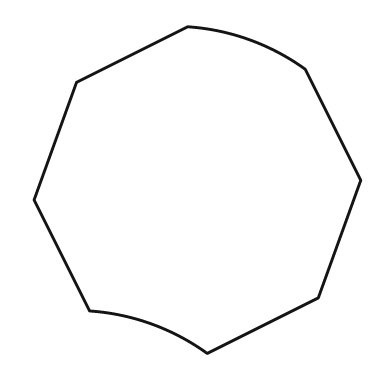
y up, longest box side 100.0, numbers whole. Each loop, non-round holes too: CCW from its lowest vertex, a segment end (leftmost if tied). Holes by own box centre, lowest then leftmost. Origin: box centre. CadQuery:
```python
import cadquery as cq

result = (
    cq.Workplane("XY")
    .moveTo(3.0, -50.0)
    .lineTo(37.0, -33.0)
    .lineTo(50.0, 3.0)
    .lineTo(33.0, 37.0)
    .threePointArc((16.0, 46.0), (-3.0, 50.0))
    .lineTo(-37.0, 33.0)
    .lineTo(-50.0, -3.0)
    .lineTo(-33.0, -37.0)
    .threePointArc((-14.0, -41.0), (3.0, -50.0))
    .close()
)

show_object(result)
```